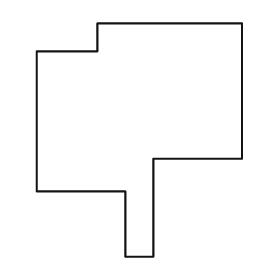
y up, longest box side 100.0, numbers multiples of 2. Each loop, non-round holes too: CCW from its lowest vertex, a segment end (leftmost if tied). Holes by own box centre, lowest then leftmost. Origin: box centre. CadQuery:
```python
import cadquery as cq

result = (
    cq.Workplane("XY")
    .moveTo(-6.0, -50.0)
    .lineTo(6.0, -50.0)
    .lineTo(6.0, -8.0)
    .lineTo(44.0, -8.0)
    .lineTo(44.0, 50.0)
    .lineTo(-18.0, 50.0)
    .lineTo(-18.0, 38.0)
    .lineTo(-44.0, 38.0)
    .lineTo(-44.0, -22.0)
    .lineTo(-6.0, -22.0)
    .close()
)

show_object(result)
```